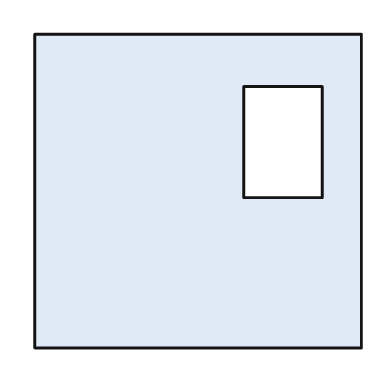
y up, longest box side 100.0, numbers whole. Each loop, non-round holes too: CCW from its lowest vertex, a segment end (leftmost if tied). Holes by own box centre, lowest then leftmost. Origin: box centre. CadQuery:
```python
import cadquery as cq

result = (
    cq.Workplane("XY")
    .moveTo(-50.0, -48.0)
    .lineTo(50.0, -48.0)
    .lineTo(50.0, 48.0)
    .lineTo(-50.0, 48.0)
    .close()
    .moveTo(14.0, -2.0)
    .lineTo(38.0, -2.0)
    .lineTo(38.0, 32.0)
    .lineTo(14.0, 32.0)
    .close()
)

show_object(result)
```